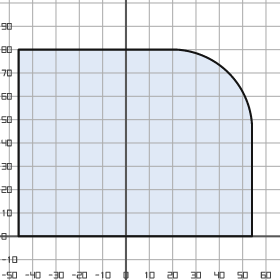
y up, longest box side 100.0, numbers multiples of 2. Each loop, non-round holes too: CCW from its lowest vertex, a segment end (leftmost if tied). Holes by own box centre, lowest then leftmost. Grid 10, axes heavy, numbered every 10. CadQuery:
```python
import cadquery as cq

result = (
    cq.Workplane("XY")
    .moveTo(-46.0, 0.0)
    .lineTo(54.0, 0.0)
    .lineTo(54.0, 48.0)
    .threePointArc((44.0, 70.0), (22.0, 80.0))
    .lineTo(-46.0, 80.0)
    .close()
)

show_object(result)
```